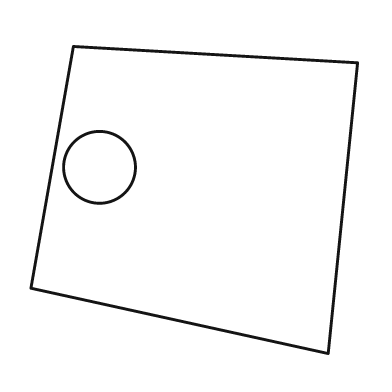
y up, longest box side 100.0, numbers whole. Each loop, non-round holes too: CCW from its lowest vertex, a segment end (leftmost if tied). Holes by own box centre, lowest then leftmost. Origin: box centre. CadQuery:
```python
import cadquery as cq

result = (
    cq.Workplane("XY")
    .moveTo(41.0, -47.0)
    .lineTo(50.0, 42.0)
    .lineTo(-37.0, 47.0)
    .lineTo(-50.0, -27.0)
    .close()
    .moveTo(-29.0, 10.0)
    .circle(11.0)
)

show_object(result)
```